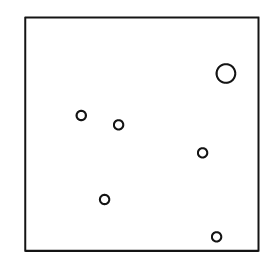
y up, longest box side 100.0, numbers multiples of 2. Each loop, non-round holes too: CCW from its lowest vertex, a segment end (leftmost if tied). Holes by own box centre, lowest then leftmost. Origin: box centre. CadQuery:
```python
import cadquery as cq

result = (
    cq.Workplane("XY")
    .moveTo(-50.0, -50.0)
    .lineTo(50.0, -50.0)
    .lineTo(50.0, 50.0)
    .lineTo(-50.0, 50.0)
    .close()
    .moveTo(32.0, -44.0)
    .circle(2.0)
    .moveTo(-16.0, -28.0)
    .circle(2.0)
    .moveTo(26.0, -8.0)
    .circle(2.0)
    .moveTo(-10.0, 4.0)
    .circle(2.0)
    .moveTo(-26.0, 8.0)
    .circle(2.0)
    .moveTo(36.0, 26.0)
    .circle(4.0)
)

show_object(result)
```